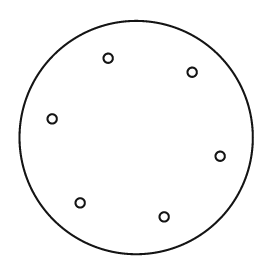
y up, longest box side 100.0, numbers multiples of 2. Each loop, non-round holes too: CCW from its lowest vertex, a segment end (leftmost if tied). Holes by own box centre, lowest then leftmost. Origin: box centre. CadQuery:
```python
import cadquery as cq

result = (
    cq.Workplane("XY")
    .moveTo(0.0, 0.0)
    .circle(50.0)
    .moveTo(12.0, -34.0)
    .circle(2.0)
    .moveTo(-24.0, -28.0)
    .circle(2.0)
    .moveTo(36.0, -8.0)
    .circle(2.0)
    .moveTo(-36.0, 8.0)
    .circle(2.0)
    .moveTo(24.0, 28.0)
    .circle(2.0)
    .moveTo(-12.0, 34.0)
    .circle(2.0)
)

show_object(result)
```